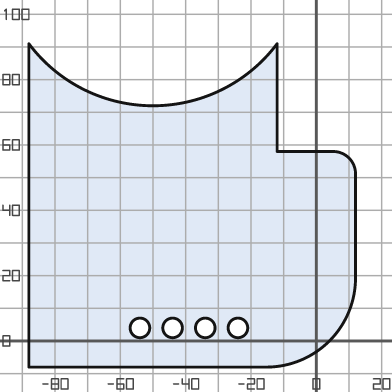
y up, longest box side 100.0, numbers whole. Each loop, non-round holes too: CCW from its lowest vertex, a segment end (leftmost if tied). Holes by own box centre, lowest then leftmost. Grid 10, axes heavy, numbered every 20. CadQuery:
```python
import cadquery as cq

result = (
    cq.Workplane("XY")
    .moveTo(-88.0, -8.0)
    .lineTo(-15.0, -8.0)
    .threePointArc((4.0, 0.0), (12.0, 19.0))
    .lineTo(12.0, 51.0)
    .threePointArc((10.0, 56.0), (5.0, 58.0))
    .lineTo(-12.0, 58.0)
    .lineTo(-12.0, 91.0)
    .threePointArc((-50.0, 72.0), (-88.0, 91.0))
    .close()
    .moveTo(-54.0, 4.0)
    .circle(3.0)
    .moveTo(-44.0, 4.0)
    .circle(3.0)
    .moveTo(-34.0, 4.0)
    .circle(3.0)
    .moveTo(-24.0, 4.0)
    .circle(3.0)
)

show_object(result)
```